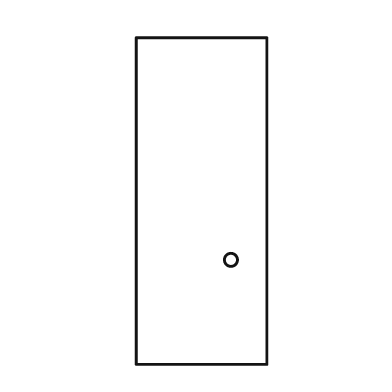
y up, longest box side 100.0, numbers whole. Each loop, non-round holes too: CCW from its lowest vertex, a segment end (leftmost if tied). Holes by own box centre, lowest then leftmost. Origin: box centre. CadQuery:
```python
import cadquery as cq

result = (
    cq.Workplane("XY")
    .moveTo(-20.0, -50.0)
    .lineTo(20.0, -50.0)
    .lineTo(20.0, 50.0)
    .lineTo(-20.0, 50.0)
    .close()
    .moveTo(9.0, -18.0)
    .circle(2.0)
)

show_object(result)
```